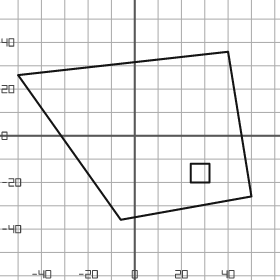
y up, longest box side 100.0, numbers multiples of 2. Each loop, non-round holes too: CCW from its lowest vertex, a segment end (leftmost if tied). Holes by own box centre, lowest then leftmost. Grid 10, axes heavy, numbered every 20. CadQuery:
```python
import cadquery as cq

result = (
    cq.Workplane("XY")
    .moveTo(-6.0, -36.0)
    .lineTo(50.0, -26.0)
    .lineTo(40.0, 36.0)
    .lineTo(-50.0, 26.0)
    .close()
    .moveTo(24.0, -20.0)
    .lineTo(32.0, -20.0)
    .lineTo(32.0, -12.0)
    .lineTo(24.0, -12.0)
    .close()
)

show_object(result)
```